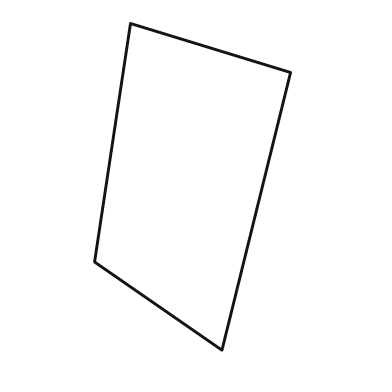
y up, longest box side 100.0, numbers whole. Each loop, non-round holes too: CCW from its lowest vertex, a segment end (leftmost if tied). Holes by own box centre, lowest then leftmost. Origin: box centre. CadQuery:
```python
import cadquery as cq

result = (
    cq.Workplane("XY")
    .moveTo(9.0, -50.0)
    .lineTo(30.0, 35.0)
    .lineTo(-19.0, 50.0)
    .lineTo(-30.0, -23.0)
    .close()
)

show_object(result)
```